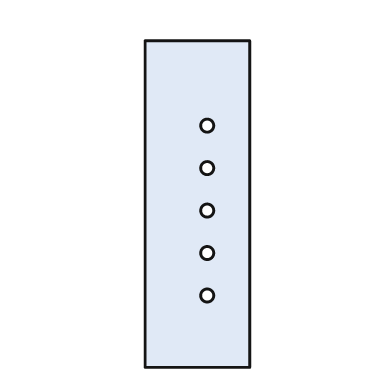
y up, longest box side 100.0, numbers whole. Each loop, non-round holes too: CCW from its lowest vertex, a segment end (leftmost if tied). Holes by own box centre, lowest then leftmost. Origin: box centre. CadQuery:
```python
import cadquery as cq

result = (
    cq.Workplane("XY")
    .moveTo(-16.0, -50.0)
    .lineTo(16.0, -50.0)
    .lineTo(16.0, 50.0)
    .lineTo(-16.0, 50.0)
    .close()
    .moveTo(3.0, -28.0)
    .circle(2.0)
    .moveTo(3.0, -15.0)
    .circle(2.0)
    .moveTo(3.0, -2.0)
    .circle(2.0)
    .moveTo(3.0, 11.0)
    .circle(2.0)
    .moveTo(3.0, 24.0)
    .circle(2.0)
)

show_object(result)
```